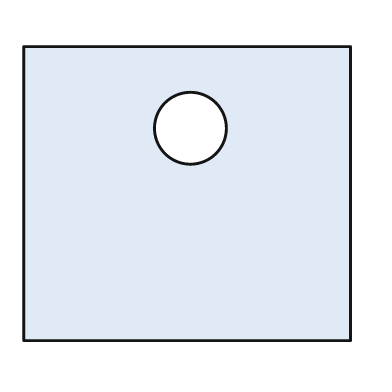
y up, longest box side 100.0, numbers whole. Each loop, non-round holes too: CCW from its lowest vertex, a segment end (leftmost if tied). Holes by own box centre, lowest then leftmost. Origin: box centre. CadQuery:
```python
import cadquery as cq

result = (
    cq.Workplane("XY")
    .moveTo(-50.0, -45.0)
    .lineTo(50.0, -45.0)
    .lineTo(50.0, 45.0)
    .lineTo(-50.0, 45.0)
    .close()
    .moveTo(1.0, 20.0)
    .circle(11.0)
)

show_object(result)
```